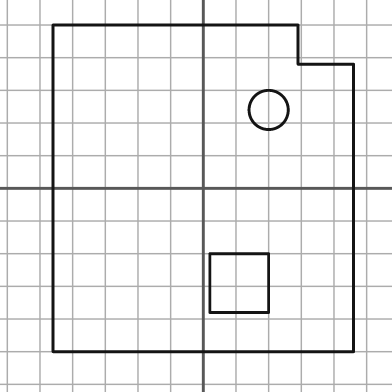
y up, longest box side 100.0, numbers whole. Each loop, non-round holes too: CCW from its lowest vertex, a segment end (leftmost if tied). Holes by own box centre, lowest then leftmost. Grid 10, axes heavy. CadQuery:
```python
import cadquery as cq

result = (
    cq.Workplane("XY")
    .moveTo(-46.0, -50.0)
    .lineTo(46.0, -50.0)
    .lineTo(46.0, 38.0)
    .lineTo(29.0, 38.0)
    .lineTo(29.0, 50.0)
    .lineTo(-46.0, 50.0)
    .close()
    .moveTo(2.0, -38.0)
    .lineTo(20.0, -38.0)
    .lineTo(20.0, -20.0)
    .lineTo(2.0, -20.0)
    .close()
    .moveTo(20.0, 24.0)
    .circle(6.0)
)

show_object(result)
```